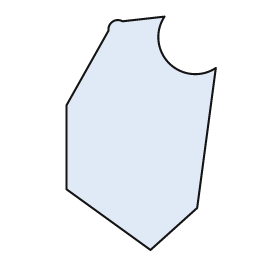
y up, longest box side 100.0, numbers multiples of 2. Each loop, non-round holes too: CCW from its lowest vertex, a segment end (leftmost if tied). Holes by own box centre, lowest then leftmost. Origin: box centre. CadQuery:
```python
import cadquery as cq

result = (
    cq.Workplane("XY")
    .moveTo(4.0, -50.0)
    .lineTo(24.0, -32.0)
    .lineTo(32.0, 28.0)
    .threePointArc((12.0, 30.0), (10.0, 50.0))
    .lineTo(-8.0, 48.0)
    .threePointArc((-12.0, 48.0), (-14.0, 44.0))
    .lineTo(-32.0, 12.0)
    .lineTo(-32.0, -24.0)
    .close()
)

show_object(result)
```